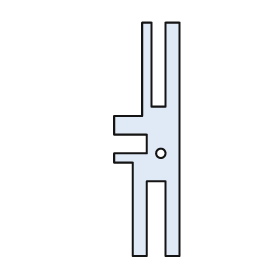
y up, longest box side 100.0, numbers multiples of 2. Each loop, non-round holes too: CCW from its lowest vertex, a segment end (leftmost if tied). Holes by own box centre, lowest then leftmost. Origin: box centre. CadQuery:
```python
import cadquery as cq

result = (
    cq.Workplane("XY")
    .moveTo(-6.0, -50.0)
    .lineTo(0.0, -50.0)
    .lineTo(0.0, -18.0)
    .lineTo(8.0, -18.0)
    .lineTo(8.0, -50.0)
    .lineTo(14.0, -50.0)
    .lineTo(14.0, 50.0)
    .lineTo(8.0, 50.0)
    .lineTo(8.0, 14.0)
    .lineTo(2.0, 14.0)
    .lineTo(2.0, 50.0)
    .lineTo(-2.0, 50.0)
    .lineTo(-2.0, 10.0)
    .lineTo(-14.0, 10.0)
    .lineTo(-14.0, 2.0)
    .lineTo(0.0, 2.0)
    .lineTo(0.0, -6.0)
    .lineTo(-14.0, -6.0)
    .lineTo(-14.0, -10.0)
    .lineTo(-6.0, -10.0)
    .close()
    .moveTo(6.0, -6.0)
    .circle(2.0)
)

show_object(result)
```